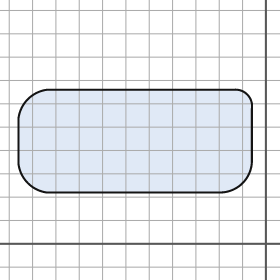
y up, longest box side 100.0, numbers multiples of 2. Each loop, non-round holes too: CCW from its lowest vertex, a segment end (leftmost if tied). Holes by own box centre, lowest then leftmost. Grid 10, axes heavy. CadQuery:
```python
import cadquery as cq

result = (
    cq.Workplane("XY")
    .moveTo(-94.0, 22.0)
    .lineTo(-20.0, 22.0)
    .threePointArc((-10.0, 26.0), (-6.0, 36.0))
    .lineTo(-6.0, 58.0)
    .threePointArc((-8.0, 64.0), (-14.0, 66.0))
    .lineTo(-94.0, 66.0)
    .threePointArc((-102.0, 62.0), (-106.0, 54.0))
    .lineTo(-106.0, 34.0)
    .threePointArc((-102.0, 26.0), (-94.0, 22.0))
    .close()
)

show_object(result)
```